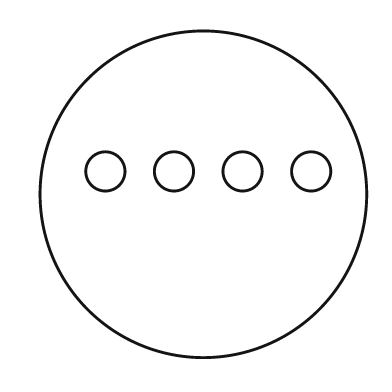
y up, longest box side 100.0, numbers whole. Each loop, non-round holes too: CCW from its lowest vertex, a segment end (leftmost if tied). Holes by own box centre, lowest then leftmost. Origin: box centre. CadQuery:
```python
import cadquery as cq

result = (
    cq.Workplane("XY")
    .moveTo(0.0, 0.0)
    .circle(50.0)
    .moveTo(-30.0, 7.0)
    .circle(6.0)
    .moveTo(-9.0, 7.0)
    .circle(6.0)
    .moveTo(12.0, 7.0)
    .circle(6.0)
    .moveTo(33.0, 7.0)
    .circle(6.0)
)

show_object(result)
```